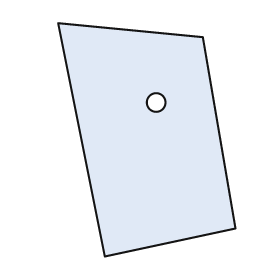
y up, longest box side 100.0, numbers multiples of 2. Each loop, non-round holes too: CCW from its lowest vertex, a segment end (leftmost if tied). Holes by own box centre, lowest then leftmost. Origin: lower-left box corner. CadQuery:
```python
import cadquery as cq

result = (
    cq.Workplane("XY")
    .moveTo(20.0, 0.0)
    .lineTo(76.0, 12.0)
    .lineTo(62.0, 94.0)
    .lineTo(0.0, 100.0)
    .close()
    .moveTo(42.0, 66.0)
    .circle(4.0)
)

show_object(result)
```